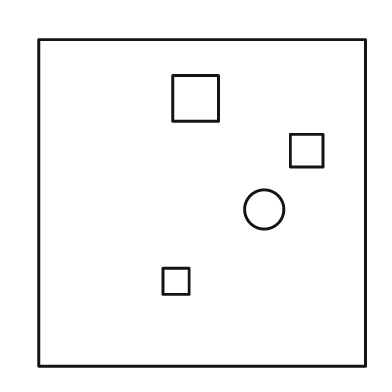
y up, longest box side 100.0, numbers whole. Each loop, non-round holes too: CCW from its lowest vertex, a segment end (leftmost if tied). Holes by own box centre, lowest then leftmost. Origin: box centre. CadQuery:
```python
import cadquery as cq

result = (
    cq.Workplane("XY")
    .moveTo(-50.0, -50.0)
    .lineTo(50.0, -50.0)
    .lineTo(50.0, 50.0)
    .lineTo(-50.0, 50.0)
    .close()
    .moveTo(-12.0, -28.0)
    .lineTo(-4.0, -28.0)
    .lineTo(-4.0, -20.0)
    .lineTo(-12.0, -20.0)
    .close()
    .moveTo(19.0, -2.0)
    .circle(6.0)
    .moveTo(27.0, 11.0)
    .lineTo(37.0, 11.0)
    .lineTo(37.0, 21.0)
    .lineTo(27.0, 21.0)
    .close()
    .moveTo(-9.0, 25.0)
    .lineTo(5.0, 25.0)
    .lineTo(5.0, 39.0)
    .lineTo(-9.0, 39.0)
    .close()
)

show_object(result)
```